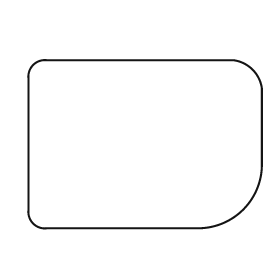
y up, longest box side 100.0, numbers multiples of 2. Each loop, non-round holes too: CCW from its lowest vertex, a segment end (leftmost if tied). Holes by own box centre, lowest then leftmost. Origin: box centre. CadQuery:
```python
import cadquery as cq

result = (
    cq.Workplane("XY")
    .moveTo(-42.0, -36.0)
    .lineTo(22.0, -36.0)
    .threePointArc((42.0, -28.0), (50.0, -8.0))
    .lineTo(50.0, 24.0)
    .threePointArc((46.0, 32.0), (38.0, 36.0))
    .lineTo(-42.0, 36.0)
    .threePointArc((-48.0, 34.0), (-50.0, 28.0))
    .lineTo(-50.0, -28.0)
    .threePointArc((-48.0, -34.0), (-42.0, -36.0))
    .close()
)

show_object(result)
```